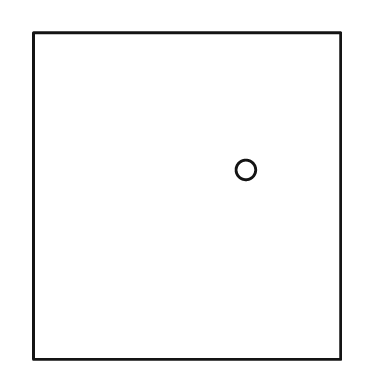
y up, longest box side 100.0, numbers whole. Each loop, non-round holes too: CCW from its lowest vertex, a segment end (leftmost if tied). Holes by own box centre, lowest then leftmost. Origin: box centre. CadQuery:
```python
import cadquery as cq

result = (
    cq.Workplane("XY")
    .moveTo(-47.0, -50.0)
    .lineTo(47.0, -50.0)
    .lineTo(47.0, 50.0)
    .lineTo(-47.0, 50.0)
    .close()
    .moveTo(18.0, 8.0)
    .circle(3.0)
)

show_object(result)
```